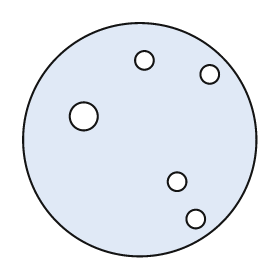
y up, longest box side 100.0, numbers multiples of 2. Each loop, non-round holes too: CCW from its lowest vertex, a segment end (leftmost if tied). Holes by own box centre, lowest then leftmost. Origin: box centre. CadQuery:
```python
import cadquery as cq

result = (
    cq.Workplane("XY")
    .moveTo(0.0, 0.0)
    .circle(50.0)
    .moveTo(24.0, -34.0)
    .circle(4.0)
    .moveTo(16.0, -18.0)
    .circle(4.0)
    .moveTo(-24.0, 10.0)
    .circle(6.0)
    .moveTo(30.0, 28.0)
    .circle(4.0)
    .moveTo(2.0, 34.0)
    .circle(4.0)
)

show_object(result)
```